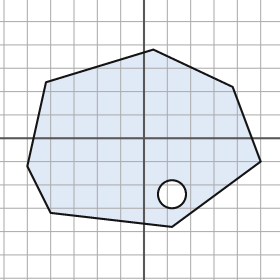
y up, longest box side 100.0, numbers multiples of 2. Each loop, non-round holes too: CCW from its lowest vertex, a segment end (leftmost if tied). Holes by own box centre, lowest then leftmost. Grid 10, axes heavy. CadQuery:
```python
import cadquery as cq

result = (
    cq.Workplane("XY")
    .moveTo(12.0, -38.0)
    .lineTo(50.0, -10.0)
    .lineTo(38.0, 22.0)
    .lineTo(4.0, 38.0)
    .lineTo(-42.0, 24.0)
    .lineTo(-50.0, -12.0)
    .lineTo(-40.0, -32.0)
    .close()
    .moveTo(12.0, -24.0)
    .circle(6.0)
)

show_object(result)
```